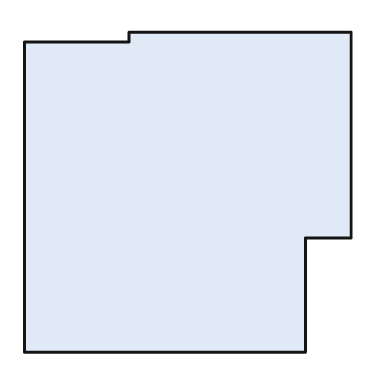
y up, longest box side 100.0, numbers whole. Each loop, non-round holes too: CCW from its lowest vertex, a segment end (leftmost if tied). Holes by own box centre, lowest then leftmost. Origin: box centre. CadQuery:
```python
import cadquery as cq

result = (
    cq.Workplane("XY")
    .moveTo(-50.0, -49.0)
    .lineTo(36.0, -49.0)
    .lineTo(36.0, -14.0)
    .lineTo(50.0, -14.0)
    .lineTo(50.0, 49.0)
    .lineTo(-18.0, 49.0)
    .lineTo(-18.0, 46.0)
    .lineTo(-50.0, 46.0)
    .close()
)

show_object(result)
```